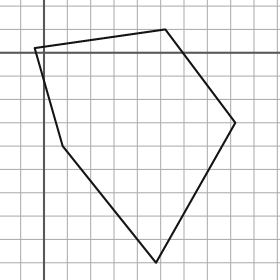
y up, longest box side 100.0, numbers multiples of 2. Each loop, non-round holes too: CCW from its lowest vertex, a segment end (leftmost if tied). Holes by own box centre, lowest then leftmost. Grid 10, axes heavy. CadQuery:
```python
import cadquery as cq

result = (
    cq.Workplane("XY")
    .moveTo(48.0, -90.0)
    .lineTo(82.0, -30.0)
    .lineTo(52.0, 10.0)
    .lineTo(-4.0, 2.0)
    .lineTo(8.0, -40.0)
    .close()
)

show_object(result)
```